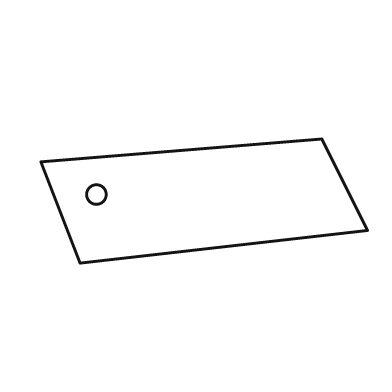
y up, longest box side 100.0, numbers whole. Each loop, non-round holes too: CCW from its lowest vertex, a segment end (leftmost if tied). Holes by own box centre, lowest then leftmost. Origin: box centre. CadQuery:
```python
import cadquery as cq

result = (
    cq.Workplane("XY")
    .moveTo(-38.0, -19.0)
    .lineTo(50.0, -9.0)
    .lineTo(36.0, 19.0)
    .lineTo(-50.0, 12.0)
    .close()
    .moveTo(-33.0, 2.0)
    .circle(3.0)
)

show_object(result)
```